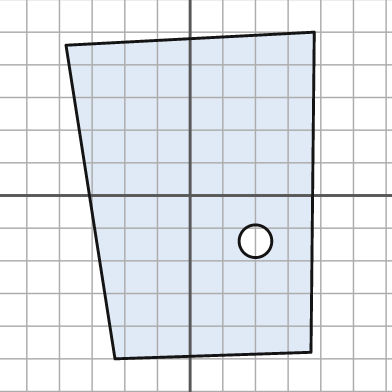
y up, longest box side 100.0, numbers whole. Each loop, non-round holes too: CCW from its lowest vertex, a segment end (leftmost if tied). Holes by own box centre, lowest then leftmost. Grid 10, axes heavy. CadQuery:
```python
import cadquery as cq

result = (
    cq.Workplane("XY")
    .moveTo(-23.0, -50.0)
    .lineTo(37.0, -48.0)
    .lineTo(38.0, 50.0)
    .lineTo(-38.0, 46.0)
    .close()
    .moveTo(20.0, -14.0)
    .circle(5.0)
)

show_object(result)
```